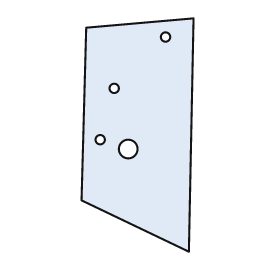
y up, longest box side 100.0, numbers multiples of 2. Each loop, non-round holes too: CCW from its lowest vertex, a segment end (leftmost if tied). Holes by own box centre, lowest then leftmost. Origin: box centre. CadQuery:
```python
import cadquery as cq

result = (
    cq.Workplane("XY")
    .moveTo(22.0, -50.0)
    .lineTo(24.0, 50.0)
    .lineTo(-22.0, 46.0)
    .lineTo(-24.0, -28.0)
    .close()
    .moveTo(-4.0, -6.0)
    .circle(4.0)
    .moveTo(-16.0, -2.0)
    .circle(2.0)
    .moveTo(-10.0, 20.0)
    .circle(2.0)
    .moveTo(12.0, 42.0)
    .circle(2.0)
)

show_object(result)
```